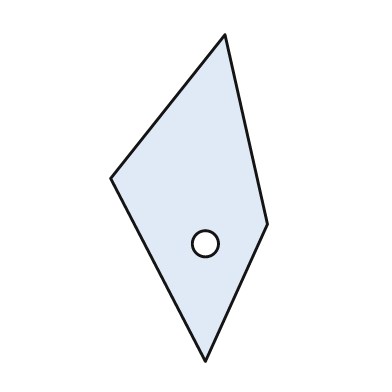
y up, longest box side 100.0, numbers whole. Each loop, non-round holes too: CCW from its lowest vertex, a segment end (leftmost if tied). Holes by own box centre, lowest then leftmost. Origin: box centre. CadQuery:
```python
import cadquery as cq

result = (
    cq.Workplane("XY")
    .moveTo(5.0, -50.0)
    .lineTo(24.0, -8.0)
    .lineTo(11.0, 50.0)
    .lineTo(-24.0, 6.0)
    .close()
    .moveTo(5.0, -14.0)
    .circle(4.0)
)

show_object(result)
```